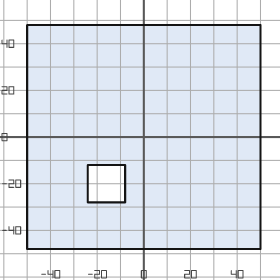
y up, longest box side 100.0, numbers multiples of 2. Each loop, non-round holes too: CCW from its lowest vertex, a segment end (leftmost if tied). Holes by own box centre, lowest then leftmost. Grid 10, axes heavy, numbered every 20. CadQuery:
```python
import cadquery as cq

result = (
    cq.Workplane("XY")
    .moveTo(-50.0, -48.0)
    .lineTo(50.0, -48.0)
    .lineTo(50.0, 48.0)
    .lineTo(-50.0, 48.0)
    .close()
    .moveTo(-24.0, -28.0)
    .lineTo(-8.0, -28.0)
    .lineTo(-8.0, -12.0)
    .lineTo(-24.0, -12.0)
    .close()
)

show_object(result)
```